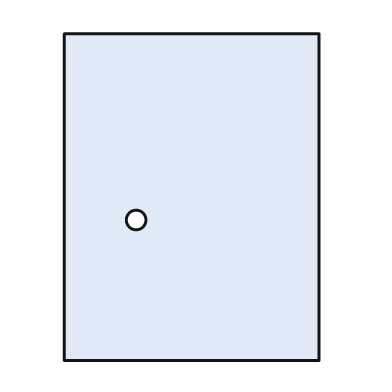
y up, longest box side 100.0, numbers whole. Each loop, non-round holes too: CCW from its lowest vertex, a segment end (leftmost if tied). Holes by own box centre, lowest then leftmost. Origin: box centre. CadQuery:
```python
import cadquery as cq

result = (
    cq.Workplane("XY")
    .moveTo(-39.0, -50.0)
    .lineTo(39.0, -50.0)
    .lineTo(39.0, 50.0)
    .lineTo(-39.0, 50.0)
    .close()
    .moveTo(-17.0, -7.0)
    .circle(3.0)
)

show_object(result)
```